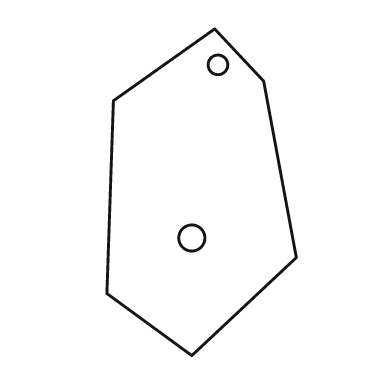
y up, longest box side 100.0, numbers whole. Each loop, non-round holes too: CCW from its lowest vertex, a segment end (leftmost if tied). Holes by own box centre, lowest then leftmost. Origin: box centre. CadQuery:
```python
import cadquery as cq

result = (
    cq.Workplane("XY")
    .moveTo(-3.0, -50.0)
    .lineTo(29.0, -20.0)
    .lineTo(19.0, 34.0)
    .lineTo(4.0, 50.0)
    .lineTo(-27.0, 28.0)
    .lineTo(-29.0, -31.0)
    .close()
    .moveTo(-3.0, -14.0)
    .circle(4.0)
    .moveTo(5.0, 39.0)
    .circle(3.0)
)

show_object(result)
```